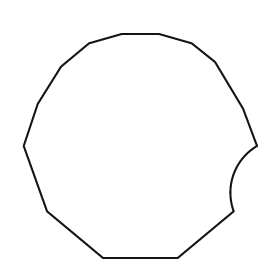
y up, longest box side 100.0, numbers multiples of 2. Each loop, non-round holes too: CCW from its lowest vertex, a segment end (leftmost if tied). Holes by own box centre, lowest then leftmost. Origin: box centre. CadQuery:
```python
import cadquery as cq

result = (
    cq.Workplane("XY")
    .moveTo(-16.0, -48.0)
    .lineTo(16.0, -48.0)
    .lineTo(40.0, -28.0)
    .threePointArc((40.0, -12.0), (50.0, 0.0))
    .lineTo(44.0, 16.0)
    .lineTo(32.0, 36.0)
    .lineTo(22.0, 44.0)
    .lineTo(8.0, 48.0)
    .lineTo(-8.0, 48.0)
    .lineTo(-22.0, 44.0)
    .lineTo(-34.0, 34.0)
    .lineTo(-44.0, 18.0)
    .lineTo(-50.0, 0.0)
    .lineTo(-40.0, -28.0)
    .close()
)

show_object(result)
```